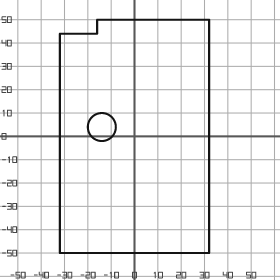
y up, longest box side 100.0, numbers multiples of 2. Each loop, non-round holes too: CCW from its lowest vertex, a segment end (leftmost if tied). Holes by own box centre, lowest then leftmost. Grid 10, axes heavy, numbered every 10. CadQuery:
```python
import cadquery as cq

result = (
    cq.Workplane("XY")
    .moveTo(-32.0, -50.0)
    .lineTo(32.0, -50.0)
    .lineTo(32.0, 50.0)
    .lineTo(-16.0, 50.0)
    .lineTo(-16.0, 44.0)
    .lineTo(-32.0, 44.0)
    .close()
    .moveTo(-14.0, 4.0)
    .circle(6.0)
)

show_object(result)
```